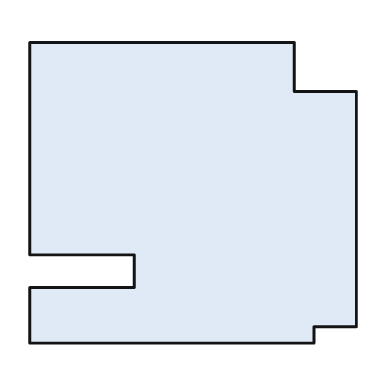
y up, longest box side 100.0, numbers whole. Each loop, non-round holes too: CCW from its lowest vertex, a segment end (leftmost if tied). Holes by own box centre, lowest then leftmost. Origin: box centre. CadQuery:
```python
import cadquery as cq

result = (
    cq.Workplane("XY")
    .moveTo(-50.0, -46.0)
    .lineTo(37.0, -46.0)
    .lineTo(37.0, -41.0)
    .lineTo(50.0, -41.0)
    .lineTo(50.0, 31.0)
    .lineTo(31.0, 31.0)
    .lineTo(31.0, 46.0)
    .lineTo(-50.0, 46.0)
    .lineTo(-50.0, -19.0)
    .lineTo(-18.0, -19.0)
    .lineTo(-18.0, -29.0)
    .lineTo(-50.0, -29.0)
    .close()
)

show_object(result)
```